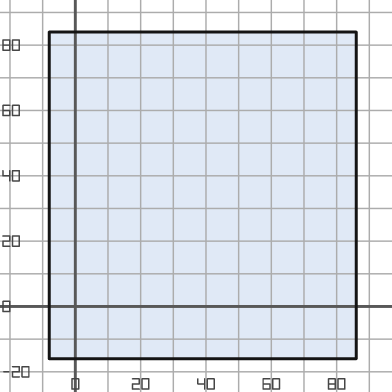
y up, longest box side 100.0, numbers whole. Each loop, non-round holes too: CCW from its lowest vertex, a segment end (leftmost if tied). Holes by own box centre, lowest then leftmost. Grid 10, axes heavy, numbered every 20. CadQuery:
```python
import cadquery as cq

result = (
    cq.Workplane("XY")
    .moveTo(-8.0, -16.0)
    .lineTo(86.0, -16.0)
    .lineTo(86.0, 84.0)
    .lineTo(-8.0, 84.0)
    .close()
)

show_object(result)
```